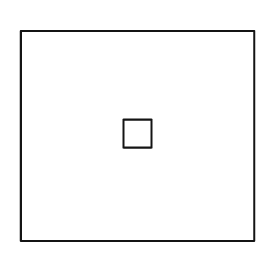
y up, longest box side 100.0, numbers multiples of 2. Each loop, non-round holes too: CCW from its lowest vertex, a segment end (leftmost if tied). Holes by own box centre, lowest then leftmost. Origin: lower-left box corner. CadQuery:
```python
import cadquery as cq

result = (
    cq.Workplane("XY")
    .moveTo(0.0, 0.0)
    .lineTo(100.0, 0.0)
    .lineTo(100.0, 90.0)
    .lineTo(0.0, 90.0)
    .close()
    .moveTo(44.0, 40.0)
    .lineTo(56.0, 40.0)
    .lineTo(56.0, 52.0)
    .lineTo(44.0, 52.0)
    .close()
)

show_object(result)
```